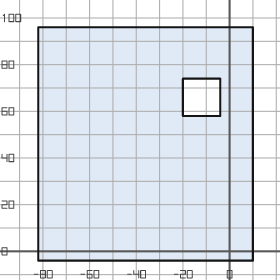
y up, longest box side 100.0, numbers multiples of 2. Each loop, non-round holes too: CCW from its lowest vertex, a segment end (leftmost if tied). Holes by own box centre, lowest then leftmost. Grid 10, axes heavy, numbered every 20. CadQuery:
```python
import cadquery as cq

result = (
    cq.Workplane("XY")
    .moveTo(-82.0, -4.0)
    .lineTo(10.0, -4.0)
    .lineTo(10.0, 96.0)
    .lineTo(-82.0, 96.0)
    .close()
    .moveTo(-20.0, 58.0)
    .lineTo(-4.0, 58.0)
    .lineTo(-4.0, 74.0)
    .lineTo(-20.0, 74.0)
    .close()
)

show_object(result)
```